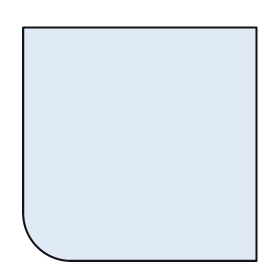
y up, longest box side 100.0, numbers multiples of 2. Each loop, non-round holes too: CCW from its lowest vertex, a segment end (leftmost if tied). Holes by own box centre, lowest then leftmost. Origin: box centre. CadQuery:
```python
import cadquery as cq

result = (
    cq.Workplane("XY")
    .moveTo(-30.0, -50.0)
    .lineTo(50.0, -50.0)
    .lineTo(50.0, 50.0)
    .lineTo(-50.0, 50.0)
    .lineTo(-50.0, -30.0)
    .threePointArc((-44.0, -44.0), (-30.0, -50.0))
    .close()
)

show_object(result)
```